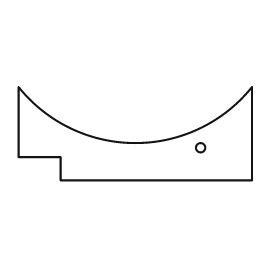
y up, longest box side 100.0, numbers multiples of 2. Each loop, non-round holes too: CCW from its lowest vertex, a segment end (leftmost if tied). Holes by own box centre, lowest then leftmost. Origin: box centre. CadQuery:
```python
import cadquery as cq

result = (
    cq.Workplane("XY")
    .moveTo(-32.0, -20.0)
    .lineTo(50.0, -20.0)
    .lineTo(50.0, 20.0)
    .threePointArc((0.0, -4.0), (-50.0, 20.0))
    .lineTo(-50.0, -10.0)
    .lineTo(-32.0, -10.0)
    .close()
    .moveTo(28.0, -6.0)
    .circle(2.0)
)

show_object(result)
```